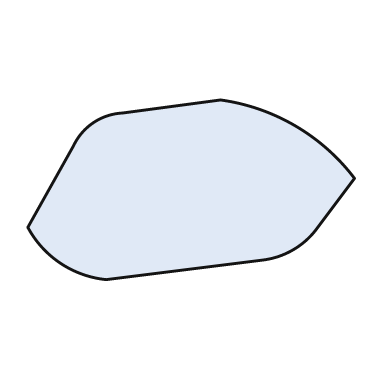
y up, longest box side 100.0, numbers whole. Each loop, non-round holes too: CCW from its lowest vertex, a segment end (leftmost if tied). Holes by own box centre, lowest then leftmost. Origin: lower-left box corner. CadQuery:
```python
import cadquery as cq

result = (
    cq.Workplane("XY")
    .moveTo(24.0, 0.0)
    .lineTo(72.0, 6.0)
    .threePointArc((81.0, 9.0), (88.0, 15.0))
    .lineTo(100.0, 31.0)
    .threePointArc((82.0, 47.0), (59.0, 55.0))
    .lineTo(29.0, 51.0)
    .threePointArc((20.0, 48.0), (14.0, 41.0))
    .lineTo(0.0, 16.0)
    .threePointArc((10.0, 5.0), (24.0, 0.0))
    .close()
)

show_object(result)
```